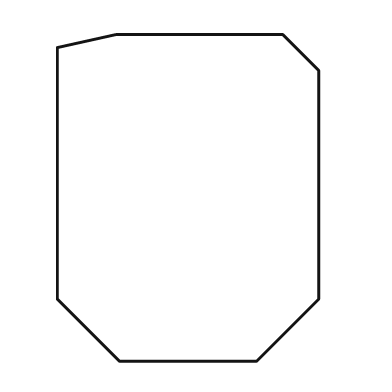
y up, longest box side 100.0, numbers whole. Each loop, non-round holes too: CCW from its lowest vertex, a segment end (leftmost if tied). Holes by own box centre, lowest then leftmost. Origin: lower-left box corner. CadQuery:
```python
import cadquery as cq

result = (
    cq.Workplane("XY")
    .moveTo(19.0, 0.0)
    .lineTo(61.0, 0.0)
    .lineTo(80.0, 19.0)
    .lineTo(80.0, 89.0)
    .lineTo(69.0, 100.0)
    .lineTo(18.0, 100.0)
    .lineTo(0.0, 96.0)
    .lineTo(0.0, 19.0)
    .close()
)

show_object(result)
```